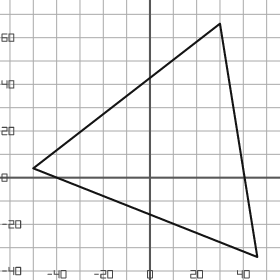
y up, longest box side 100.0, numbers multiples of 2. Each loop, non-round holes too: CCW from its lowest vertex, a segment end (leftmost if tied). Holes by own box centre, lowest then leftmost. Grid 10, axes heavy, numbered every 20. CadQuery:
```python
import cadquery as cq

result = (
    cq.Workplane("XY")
    .moveTo(46.0, -34.0)
    .lineTo(30.0, 66.0)
    .lineTo(-50.0, 4.0)
    .close()
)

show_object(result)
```